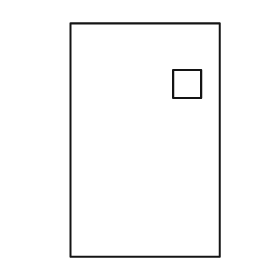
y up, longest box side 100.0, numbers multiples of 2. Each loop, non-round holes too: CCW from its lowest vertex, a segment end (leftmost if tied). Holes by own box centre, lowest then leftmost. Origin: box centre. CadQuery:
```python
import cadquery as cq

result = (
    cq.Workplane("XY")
    .moveTo(-32.0, -50.0)
    .lineTo(32.0, -50.0)
    .lineTo(32.0, 50.0)
    .lineTo(-32.0, 50.0)
    .close()
    .moveTo(12.0, 18.0)
    .lineTo(24.0, 18.0)
    .lineTo(24.0, 30.0)
    .lineTo(12.0, 30.0)
    .close()
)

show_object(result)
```